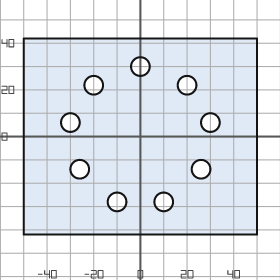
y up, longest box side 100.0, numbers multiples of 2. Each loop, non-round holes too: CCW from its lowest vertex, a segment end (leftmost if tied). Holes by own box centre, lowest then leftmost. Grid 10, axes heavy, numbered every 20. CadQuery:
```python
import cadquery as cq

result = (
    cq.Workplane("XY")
    .moveTo(-50.0, -42.0)
    .lineTo(50.0, -42.0)
    .lineTo(50.0, 42.0)
    .lineTo(-50.0, 42.0)
    .close()
    .moveTo(-10.0, -28.0)
    .circle(4.0)
    .moveTo(10.0, -28.0)
    .circle(4.0)
    .moveTo(-26.0, -14.0)
    .circle(4.0)
    .moveTo(26.0, -14.0)
    .circle(4.0)
    .moveTo(-30.0, 6.0)
    .circle(4.0)
    .moveTo(30.0, 6.0)
    .circle(4.0)
    .moveTo(-20.0, 22.0)
    .circle(4.0)
    .moveTo(20.0, 22.0)
    .circle(4.0)
    .moveTo(0.0, 30.0)
    .circle(4.0)
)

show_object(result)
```